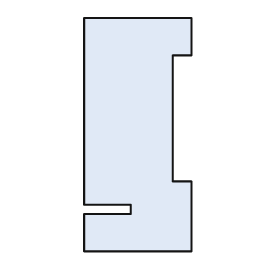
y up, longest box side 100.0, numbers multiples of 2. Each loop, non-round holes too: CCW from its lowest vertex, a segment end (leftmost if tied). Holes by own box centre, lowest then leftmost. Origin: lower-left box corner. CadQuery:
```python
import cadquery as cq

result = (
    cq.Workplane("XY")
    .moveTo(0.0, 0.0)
    .lineTo(46.0, 0.0)
    .lineTo(46.0, 30.0)
    .lineTo(38.0, 30.0)
    .lineTo(38.0, 84.0)
    .lineTo(46.0, 84.0)
    .lineTo(46.0, 100.0)
    .lineTo(0.0, 100.0)
    .lineTo(0.0, 20.0)
    .lineTo(20.0, 20.0)
    .lineTo(20.0, 16.0)
    .lineTo(0.0, 16.0)
    .close()
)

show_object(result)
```